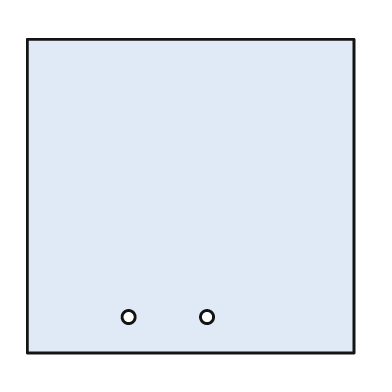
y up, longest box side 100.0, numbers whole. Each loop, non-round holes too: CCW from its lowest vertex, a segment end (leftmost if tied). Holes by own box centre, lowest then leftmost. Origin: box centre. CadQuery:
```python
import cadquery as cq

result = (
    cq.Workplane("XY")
    .moveTo(-50.0, -48.0)
    .lineTo(50.0, -48.0)
    .lineTo(50.0, 48.0)
    .lineTo(-50.0, 48.0)
    .close()
    .moveTo(-19.0, -37.0)
    .circle(2.0)
    .moveTo(5.0, -37.0)
    .circle(2.0)
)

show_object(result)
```